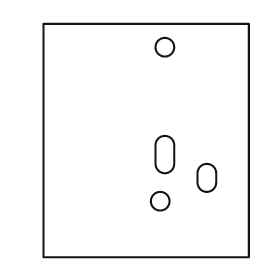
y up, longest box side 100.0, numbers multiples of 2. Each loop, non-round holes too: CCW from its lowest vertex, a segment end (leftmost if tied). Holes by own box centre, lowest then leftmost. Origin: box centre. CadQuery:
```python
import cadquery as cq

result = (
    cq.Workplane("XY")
    .moveTo(-44.0, -50.0)
    .lineTo(44.0, -50.0)
    .lineTo(44.0, 50.0)
    .lineTo(-44.0, 50.0)
    .close()
    .moveTo(6.0, -26.0)
    .circle(4.0)
    .moveTo(22.0, -18.0)
    .threePointArc((26.0, -22.0), (30.0, -18.0))
    .lineTo(30.0, -14.0)
    .threePointArc((26.0, -10.0), (22.0, -14.0))
    .close()
    .moveTo(4.0, -10.0)
    .threePointArc((8.0, -14.0), (12.0, -10.0))
    .lineTo(12.0, -2.0)
    .threePointArc((8.0, 2.0), (4.0, -2.0))
    .close()
    .moveTo(8.0, 40.0)
    .circle(4.0)
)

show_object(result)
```